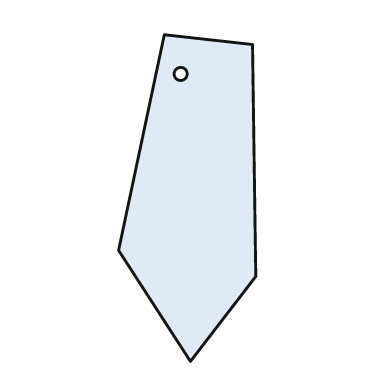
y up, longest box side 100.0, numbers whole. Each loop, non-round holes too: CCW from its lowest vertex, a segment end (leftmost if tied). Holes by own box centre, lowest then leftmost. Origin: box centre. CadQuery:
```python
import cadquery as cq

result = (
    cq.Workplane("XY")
    .moveTo(1.0, -50.0)
    .lineTo(21.0, -24.0)
    .lineTo(20.0, 47.0)
    .lineTo(-7.0, 50.0)
    .lineTo(-21.0, -16.0)
    .close()
    .moveTo(-2.0, 38.0)
    .circle(2.0)
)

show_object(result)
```